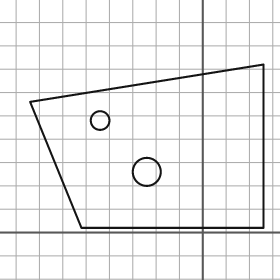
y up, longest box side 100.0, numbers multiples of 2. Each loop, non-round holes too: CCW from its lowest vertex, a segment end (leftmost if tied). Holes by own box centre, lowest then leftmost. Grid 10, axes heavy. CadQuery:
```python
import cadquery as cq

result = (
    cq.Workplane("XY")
    .moveTo(-52.0, 2.0)
    .lineTo(26.0, 2.0)
    .lineTo(26.0, 72.0)
    .lineTo(-74.0, 56.0)
    .close()
    .moveTo(-24.0, 26.0)
    .circle(6.0)
    .moveTo(-44.0, 48.0)
    .circle(4.0)
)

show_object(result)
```